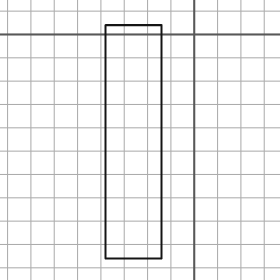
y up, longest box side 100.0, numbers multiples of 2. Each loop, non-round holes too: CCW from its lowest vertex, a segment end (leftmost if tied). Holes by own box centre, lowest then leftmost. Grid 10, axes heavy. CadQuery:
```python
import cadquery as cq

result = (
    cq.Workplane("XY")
    .moveTo(-38.0, -96.0)
    .lineTo(-14.0, -96.0)
    .lineTo(-14.0, 4.0)
    .lineTo(-38.0, 4.0)
    .close()
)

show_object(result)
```